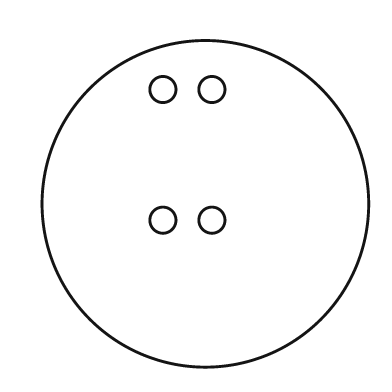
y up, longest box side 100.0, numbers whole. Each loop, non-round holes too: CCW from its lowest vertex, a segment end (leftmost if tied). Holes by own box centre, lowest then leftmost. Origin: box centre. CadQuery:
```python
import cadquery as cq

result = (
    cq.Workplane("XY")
    .moveTo(0.0, 0.0)
    .circle(50.0)
    .moveTo(-13.0, -5.0)
    .circle(4.0)
    .moveTo(2.0, -5.0)
    .circle(4.0)
    .moveTo(-13.0, 35.0)
    .circle(4.0)
    .moveTo(2.0, 35.0)
    .circle(4.0)
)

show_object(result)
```